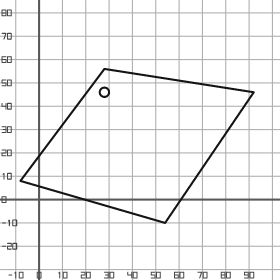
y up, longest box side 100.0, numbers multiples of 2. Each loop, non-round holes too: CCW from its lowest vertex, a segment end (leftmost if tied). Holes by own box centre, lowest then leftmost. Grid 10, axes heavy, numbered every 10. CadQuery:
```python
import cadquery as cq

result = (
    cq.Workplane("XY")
    .moveTo(54.0, -10.0)
    .lineTo(92.0, 46.0)
    .lineTo(28.0, 56.0)
    .lineTo(-8.0, 8.0)
    .close()
    .moveTo(28.0, 46.0)
    .circle(2.0)
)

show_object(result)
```